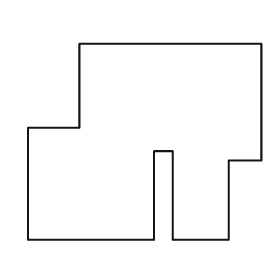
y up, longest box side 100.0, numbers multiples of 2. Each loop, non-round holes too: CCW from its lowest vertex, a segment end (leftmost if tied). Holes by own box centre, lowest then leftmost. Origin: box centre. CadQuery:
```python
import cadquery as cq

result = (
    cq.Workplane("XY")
    .moveTo(-50.0, -42.0)
    .lineTo(4.0, -42.0)
    .lineTo(4.0, -4.0)
    .lineTo(12.0, -4.0)
    .lineTo(12.0, -42.0)
    .lineTo(36.0, -42.0)
    .lineTo(36.0, -8.0)
    .lineTo(50.0, -8.0)
    .lineTo(50.0, 42.0)
    .lineTo(-28.0, 42.0)
    .lineTo(-28.0, 6.0)
    .lineTo(-50.0, 6.0)
    .close()
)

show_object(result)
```